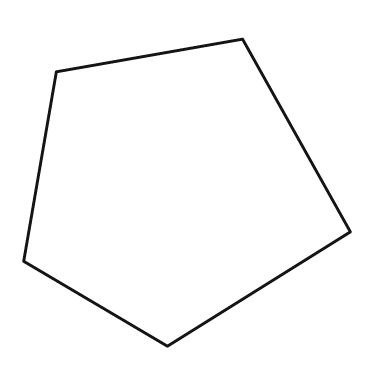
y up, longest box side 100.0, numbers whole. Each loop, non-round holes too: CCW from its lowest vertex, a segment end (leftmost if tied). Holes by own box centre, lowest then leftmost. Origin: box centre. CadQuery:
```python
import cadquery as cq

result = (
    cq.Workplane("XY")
    .moveTo(-6.0, -47.0)
    .lineTo(50.0, -12.0)
    .lineTo(17.0, 47.0)
    .lineTo(-40.0, 37.0)
    .lineTo(-50.0, -21.0)
    .close()
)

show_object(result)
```